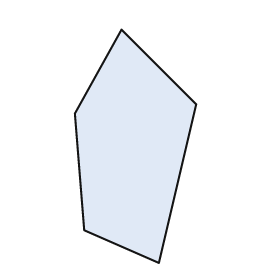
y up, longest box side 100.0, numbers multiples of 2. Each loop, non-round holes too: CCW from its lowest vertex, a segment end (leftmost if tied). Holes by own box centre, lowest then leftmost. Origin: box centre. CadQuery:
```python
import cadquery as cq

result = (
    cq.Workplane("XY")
    .moveTo(10.0, -50.0)
    .lineTo(26.0, 18.0)
    .lineTo(-6.0, 50.0)
    .lineTo(-26.0, 14.0)
    .lineTo(-22.0, -36.0)
    .close()
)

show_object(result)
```